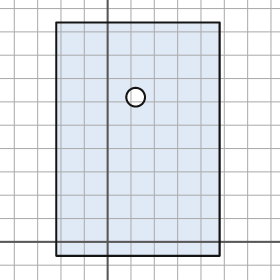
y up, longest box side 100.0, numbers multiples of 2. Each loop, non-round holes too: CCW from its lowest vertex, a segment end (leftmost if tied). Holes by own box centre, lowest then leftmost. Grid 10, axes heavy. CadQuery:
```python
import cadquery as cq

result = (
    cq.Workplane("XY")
    .moveTo(-22.0, -6.0)
    .lineTo(48.0, -6.0)
    .lineTo(48.0, 94.0)
    .lineTo(-22.0, 94.0)
    .close()
    .moveTo(12.0, 62.0)
    .circle(4.0)
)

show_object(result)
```